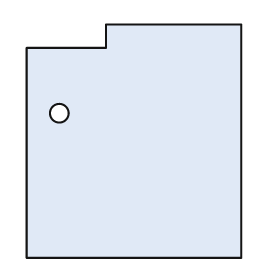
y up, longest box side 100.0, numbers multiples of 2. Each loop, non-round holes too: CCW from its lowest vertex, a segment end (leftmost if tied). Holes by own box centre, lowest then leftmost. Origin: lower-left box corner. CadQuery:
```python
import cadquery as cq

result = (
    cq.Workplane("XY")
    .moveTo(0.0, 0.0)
    .lineTo(92.0, 0.0)
    .lineTo(92.0, 100.0)
    .lineTo(34.0, 100.0)
    .lineTo(34.0, 90.0)
    .lineTo(0.0, 90.0)
    .close()
    .moveTo(14.0, 62.0)
    .circle(4.0)
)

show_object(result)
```